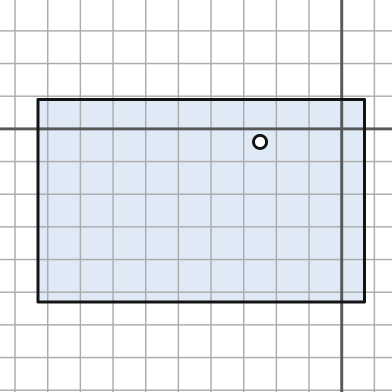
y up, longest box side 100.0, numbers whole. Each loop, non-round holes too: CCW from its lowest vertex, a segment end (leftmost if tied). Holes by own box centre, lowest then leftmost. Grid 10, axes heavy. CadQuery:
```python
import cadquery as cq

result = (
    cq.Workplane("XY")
    .moveTo(-93.0, -53.0)
    .lineTo(7.0, -53.0)
    .lineTo(7.0, 9.0)
    .lineTo(-93.0, 9.0)
    .close()
    .moveTo(-25.0, -4.0)
    .circle(2.0)
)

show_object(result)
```